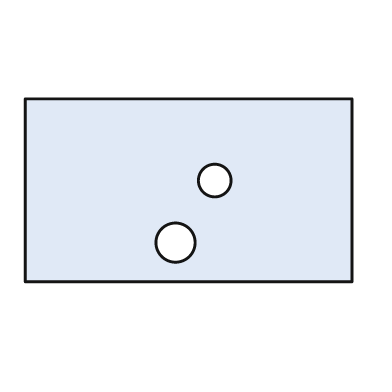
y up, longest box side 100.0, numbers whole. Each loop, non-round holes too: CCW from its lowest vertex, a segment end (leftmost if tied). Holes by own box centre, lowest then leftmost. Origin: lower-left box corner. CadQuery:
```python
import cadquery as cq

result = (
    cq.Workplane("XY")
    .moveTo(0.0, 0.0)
    .lineTo(100.0, 0.0)
    .lineTo(100.0, 56.0)
    .lineTo(0.0, 56.0)
    .close()
    .moveTo(46.0, 12.0)
    .circle(6.0)
    .moveTo(58.0, 31.0)
    .circle(5.0)
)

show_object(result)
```